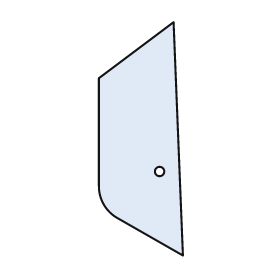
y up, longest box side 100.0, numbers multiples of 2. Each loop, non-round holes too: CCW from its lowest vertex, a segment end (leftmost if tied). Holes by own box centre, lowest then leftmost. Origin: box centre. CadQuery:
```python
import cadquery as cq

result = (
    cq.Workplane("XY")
    .moveTo(18.0, -50.0)
    .lineTo(14.0, 50.0)
    .lineTo(-18.0, 26.0)
    .lineTo(-18.0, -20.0)
    .threePointArc((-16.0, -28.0), (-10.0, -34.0))
    .close()
    .moveTo(8.0, -14.0)
    .circle(2.0)
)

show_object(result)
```